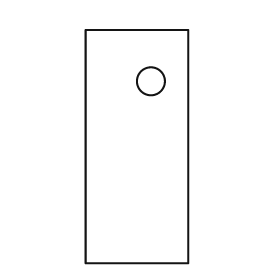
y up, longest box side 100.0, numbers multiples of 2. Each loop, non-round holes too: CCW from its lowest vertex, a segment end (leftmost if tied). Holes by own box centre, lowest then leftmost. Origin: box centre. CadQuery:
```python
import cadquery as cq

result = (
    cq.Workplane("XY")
    .moveTo(-22.0, -50.0)
    .lineTo(22.0, -50.0)
    .lineTo(22.0, 50.0)
    .lineTo(-22.0, 50.0)
    .close()
    .moveTo(6.0, 28.0)
    .circle(6.0)
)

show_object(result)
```